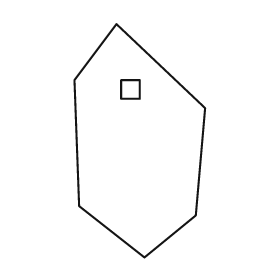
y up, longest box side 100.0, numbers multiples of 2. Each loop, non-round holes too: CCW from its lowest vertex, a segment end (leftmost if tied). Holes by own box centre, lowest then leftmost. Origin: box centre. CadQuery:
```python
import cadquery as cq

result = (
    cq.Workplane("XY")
    .moveTo(2.0, -50.0)
    .lineTo(24.0, -32.0)
    .lineTo(28.0, 14.0)
    .lineTo(-10.0, 50.0)
    .lineTo(-28.0, 26.0)
    .lineTo(-26.0, -28.0)
    .close()
    .moveTo(-8.0, 18.0)
    .lineTo(0.0, 18.0)
    .lineTo(0.0, 26.0)
    .lineTo(-8.0, 26.0)
    .close()
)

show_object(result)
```